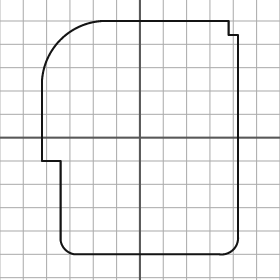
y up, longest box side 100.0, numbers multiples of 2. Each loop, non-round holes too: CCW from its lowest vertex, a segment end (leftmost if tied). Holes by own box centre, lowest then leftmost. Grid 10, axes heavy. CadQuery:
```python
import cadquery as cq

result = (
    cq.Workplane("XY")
    .moveTo(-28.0, -50.0)
    .lineTo(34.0, -50.0)
    .threePointArc((40.0, -48.0), (42.0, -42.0))
    .lineTo(42.0, 44.0)
    .lineTo(38.0, 44.0)
    .lineTo(38.0, 50.0)
    .lineTo(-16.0, 50.0)
    .threePointArc((-34.0, 42.0), (-42.0, 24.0))
    .lineTo(-42.0, -10.0)
    .lineTo(-34.0, -10.0)
    .lineTo(-34.0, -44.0)
    .threePointArc((-32.0, -48.0), (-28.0, -50.0))
    .close()
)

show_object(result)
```